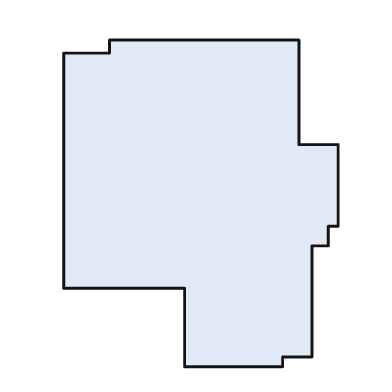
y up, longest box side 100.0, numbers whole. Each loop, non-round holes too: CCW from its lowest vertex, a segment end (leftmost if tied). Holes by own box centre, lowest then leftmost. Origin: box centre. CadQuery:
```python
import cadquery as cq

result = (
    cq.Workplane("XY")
    .moveTo(-5.0, -50.0)
    .lineTo(25.0, -50.0)
    .lineTo(25.0, -47.0)
    .lineTo(34.0, -47.0)
    .lineTo(34.0, -13.0)
    .lineTo(39.0, -13.0)
    .lineTo(39.0, -7.0)
    .lineTo(42.0, -7.0)
    .lineTo(42.0, 18.0)
    .lineTo(30.0, 18.0)
    .lineTo(30.0, 50.0)
    .lineTo(-28.0, 50.0)
    .lineTo(-28.0, 46.0)
    .lineTo(-42.0, 46.0)
    .lineTo(-42.0, -26.0)
    .lineTo(-5.0, -26.0)
    .close()
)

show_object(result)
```